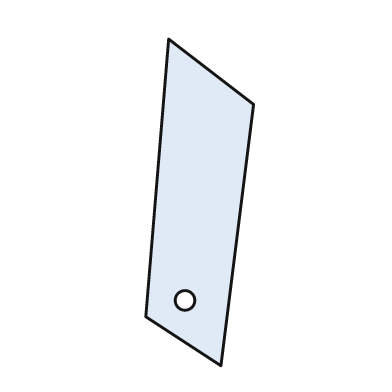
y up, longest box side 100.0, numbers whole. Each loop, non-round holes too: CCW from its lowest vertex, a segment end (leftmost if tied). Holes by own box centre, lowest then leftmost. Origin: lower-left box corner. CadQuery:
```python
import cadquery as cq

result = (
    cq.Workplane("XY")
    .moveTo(23.0, 0.0)
    .lineTo(33.0, 80.0)
    .lineTo(7.0, 100.0)
    .lineTo(0.0, 15.0)
    .close()
    .moveTo(12.0, 20.0)
    .circle(3.0)
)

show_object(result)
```